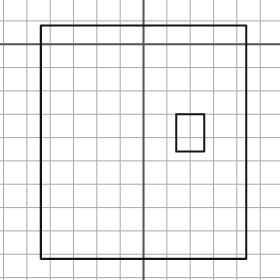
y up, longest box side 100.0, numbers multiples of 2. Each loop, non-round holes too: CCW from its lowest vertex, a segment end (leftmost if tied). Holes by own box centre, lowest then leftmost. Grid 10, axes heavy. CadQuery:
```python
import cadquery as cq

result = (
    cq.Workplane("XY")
    .moveTo(-44.0, -92.0)
    .lineTo(44.0, -92.0)
    .lineTo(44.0, 8.0)
    .lineTo(-44.0, 8.0)
    .close()
    .moveTo(14.0, -46.0)
    .lineTo(26.0, -46.0)
    .lineTo(26.0, -30.0)
    .lineTo(14.0, -30.0)
    .close()
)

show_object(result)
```